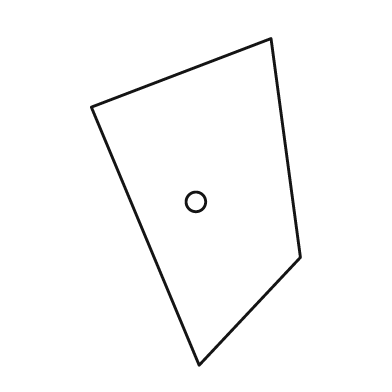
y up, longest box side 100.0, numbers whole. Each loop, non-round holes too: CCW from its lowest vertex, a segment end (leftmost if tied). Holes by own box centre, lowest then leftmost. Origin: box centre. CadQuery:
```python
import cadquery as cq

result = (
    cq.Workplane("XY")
    .moveTo(1.0, -50.0)
    .lineTo(32.0, -17.0)
    .lineTo(23.0, 50.0)
    .lineTo(-32.0, 29.0)
    .close()
    .moveTo(0.0, 0.0)
    .circle(3.0)
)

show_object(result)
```